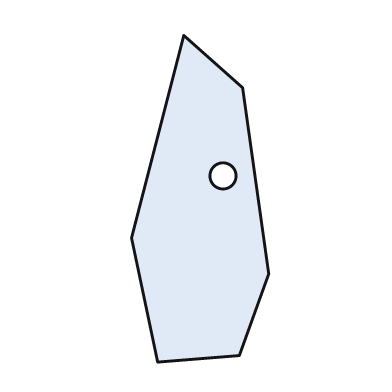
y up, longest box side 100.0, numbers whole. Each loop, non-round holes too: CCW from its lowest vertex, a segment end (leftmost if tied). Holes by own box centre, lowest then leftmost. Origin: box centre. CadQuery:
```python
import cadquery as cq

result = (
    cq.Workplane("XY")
    .moveTo(-13.0, -50.0)
    .lineTo(12.0, -48.0)
    .lineTo(21.0, -23.0)
    .lineTo(13.0, 34.0)
    .lineTo(-5.0, 50.0)
    .lineTo(-21.0, -12.0)
    .close()
    .moveTo(7.0, 7.0)
    .circle(4.0)
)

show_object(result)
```